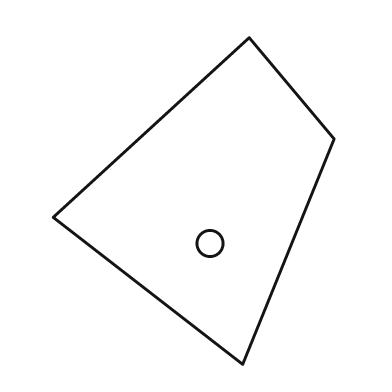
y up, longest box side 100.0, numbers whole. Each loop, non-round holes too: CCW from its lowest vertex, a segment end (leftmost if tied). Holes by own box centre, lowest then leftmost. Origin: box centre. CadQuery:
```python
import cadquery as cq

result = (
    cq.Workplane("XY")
    .moveTo(15.0, -50.0)
    .lineTo(43.0, 19.0)
    .lineTo(17.0, 50.0)
    .lineTo(-43.0, -5.0)
    .close()
    .moveTo(5.0, -13.0)
    .circle(4.0)
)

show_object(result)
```